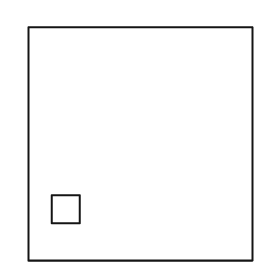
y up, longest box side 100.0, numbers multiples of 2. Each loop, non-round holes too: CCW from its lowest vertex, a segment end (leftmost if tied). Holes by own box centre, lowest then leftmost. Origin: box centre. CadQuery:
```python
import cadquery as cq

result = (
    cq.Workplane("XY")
    .moveTo(-48.0, -50.0)
    .lineTo(48.0, -50.0)
    .lineTo(48.0, 50.0)
    .lineTo(-48.0, 50.0)
    .close()
    .moveTo(-38.0, -34.0)
    .lineTo(-26.0, -34.0)
    .lineTo(-26.0, -22.0)
    .lineTo(-38.0, -22.0)
    .close()
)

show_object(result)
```